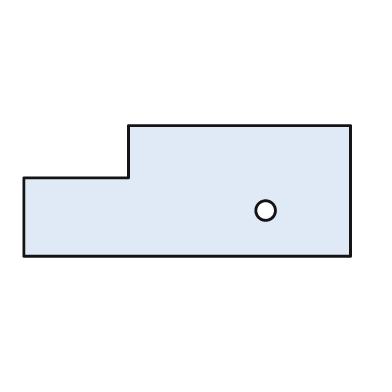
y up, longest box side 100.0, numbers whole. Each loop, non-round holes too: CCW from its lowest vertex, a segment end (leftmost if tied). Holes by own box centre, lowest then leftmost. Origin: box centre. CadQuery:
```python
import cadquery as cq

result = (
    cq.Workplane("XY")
    .moveTo(-50.0, -20.0)
    .lineTo(50.0, -20.0)
    .lineTo(50.0, 20.0)
    .lineTo(-18.0, 20.0)
    .lineTo(-18.0, 4.0)
    .lineTo(-50.0, 4.0)
    .close()
    .moveTo(24.0, -6.0)
    .circle(3.0)
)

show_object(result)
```